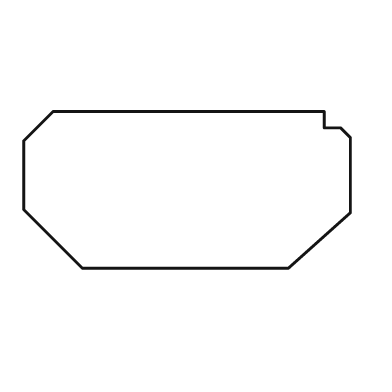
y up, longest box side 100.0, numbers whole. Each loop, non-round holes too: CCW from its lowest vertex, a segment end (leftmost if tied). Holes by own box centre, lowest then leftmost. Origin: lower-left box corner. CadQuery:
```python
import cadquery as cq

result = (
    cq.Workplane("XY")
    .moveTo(18.0, 0.0)
    .lineTo(81.0, 0.0)
    .lineTo(100.0, 17.0)
    .lineTo(100.0, 40.0)
    .lineTo(97.0, 43.0)
    .lineTo(92.0, 43.0)
    .lineTo(92.0, 48.0)
    .lineTo(9.0, 48.0)
    .lineTo(0.0, 39.0)
    .lineTo(0.0, 18.0)
    .close()
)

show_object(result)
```